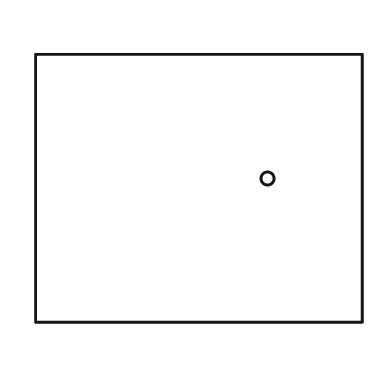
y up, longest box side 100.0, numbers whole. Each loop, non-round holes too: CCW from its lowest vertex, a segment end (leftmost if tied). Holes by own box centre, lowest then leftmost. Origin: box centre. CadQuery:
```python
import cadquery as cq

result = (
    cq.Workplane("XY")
    .moveTo(-50.0, -41.0)
    .lineTo(50.0, -41.0)
    .lineTo(50.0, 41.0)
    .lineTo(-50.0, 41.0)
    .close()
    .moveTo(21.0, 3.0)
    .circle(2.0)
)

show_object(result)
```